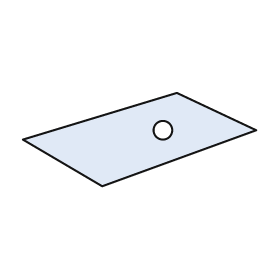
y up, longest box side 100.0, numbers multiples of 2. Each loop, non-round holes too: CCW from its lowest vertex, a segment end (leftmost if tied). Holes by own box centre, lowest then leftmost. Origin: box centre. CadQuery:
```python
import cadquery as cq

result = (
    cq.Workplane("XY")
    .moveTo(-16.0, -20.0)
    .lineTo(50.0, 4.0)
    .lineTo(16.0, 20.0)
    .lineTo(-50.0, 0.0)
    .close()
    .moveTo(10.0, 4.0)
    .circle(4.0)
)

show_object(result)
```